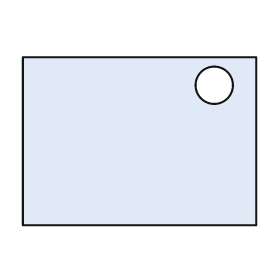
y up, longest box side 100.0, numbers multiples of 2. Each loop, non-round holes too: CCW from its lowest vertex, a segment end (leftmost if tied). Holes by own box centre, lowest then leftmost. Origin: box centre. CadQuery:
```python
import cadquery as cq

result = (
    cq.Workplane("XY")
    .moveTo(-50.0, -36.0)
    .lineTo(50.0, -36.0)
    .lineTo(50.0, 36.0)
    .lineTo(-50.0, 36.0)
    .close()
    .moveTo(32.0, 24.0)
    .circle(8.0)
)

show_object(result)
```